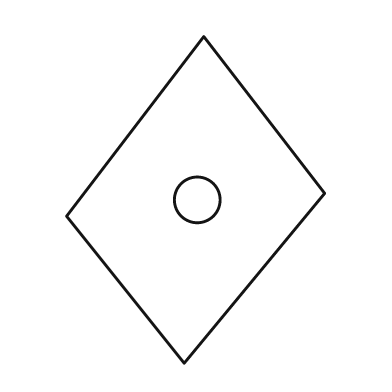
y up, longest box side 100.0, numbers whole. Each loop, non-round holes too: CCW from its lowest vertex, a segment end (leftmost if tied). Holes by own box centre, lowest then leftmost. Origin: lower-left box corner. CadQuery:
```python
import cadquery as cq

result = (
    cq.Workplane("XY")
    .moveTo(36.0, 0.0)
    .lineTo(79.0, 52.0)
    .lineTo(42.0, 100.0)
    .lineTo(0.0, 45.0)
    .close()
    .moveTo(40.0, 50.0)
    .circle(7.0)
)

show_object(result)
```